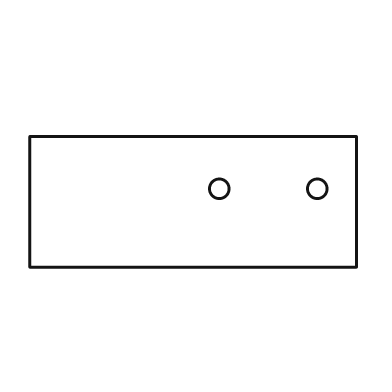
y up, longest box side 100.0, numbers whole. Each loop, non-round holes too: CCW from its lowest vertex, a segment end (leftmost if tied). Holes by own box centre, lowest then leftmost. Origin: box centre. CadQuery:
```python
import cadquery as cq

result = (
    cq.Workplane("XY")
    .moveTo(-50.0, -20.0)
    .lineTo(50.0, -20.0)
    .lineTo(50.0, 20.0)
    .lineTo(-50.0, 20.0)
    .close()
    .moveTo(8.0, 4.0)
    .circle(3.0)
    .moveTo(38.0, 4.0)
    .circle(3.0)
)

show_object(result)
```